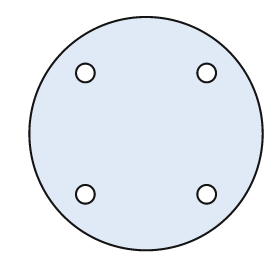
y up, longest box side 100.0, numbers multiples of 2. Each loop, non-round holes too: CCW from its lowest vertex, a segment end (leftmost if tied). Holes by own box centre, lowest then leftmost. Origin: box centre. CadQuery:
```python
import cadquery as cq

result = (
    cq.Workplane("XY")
    .moveTo(0.0, 0.0)
    .circle(50.0)
    .moveTo(-26.0, -26.0)
    .circle(4.0)
    .moveTo(26.0, -26.0)
    .circle(4.0)
    .moveTo(-26.0, 26.0)
    .circle(4.0)
    .moveTo(26.0, 26.0)
    .circle(4.0)
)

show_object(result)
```